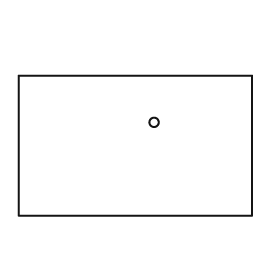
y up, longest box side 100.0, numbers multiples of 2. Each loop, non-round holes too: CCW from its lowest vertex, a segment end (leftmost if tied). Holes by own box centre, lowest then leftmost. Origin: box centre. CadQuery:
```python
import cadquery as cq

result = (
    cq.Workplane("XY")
    .moveTo(-50.0, -30.0)
    .lineTo(50.0, -30.0)
    .lineTo(50.0, 30.0)
    .lineTo(-50.0, 30.0)
    .close()
    .moveTo(8.0, 10.0)
    .circle(2.0)
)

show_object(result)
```